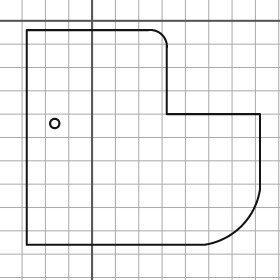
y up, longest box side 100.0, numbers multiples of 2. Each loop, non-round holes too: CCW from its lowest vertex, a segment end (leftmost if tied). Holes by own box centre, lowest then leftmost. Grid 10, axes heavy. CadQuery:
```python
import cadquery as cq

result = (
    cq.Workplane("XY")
    .moveTo(-28.0, -96.0)
    .lineTo(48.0, -96.0)
    .threePointArc((64.0, -88.0), (72.0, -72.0))
    .lineTo(72.0, -40.0)
    .lineTo(32.0, -40.0)
    .lineTo(32.0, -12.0)
    .threePointArc((30.0, -6.0), (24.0, -4.0))
    .lineTo(-28.0, -4.0)
    .close()
    .moveTo(-16.0, -44.0)
    .circle(2.0)
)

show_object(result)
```